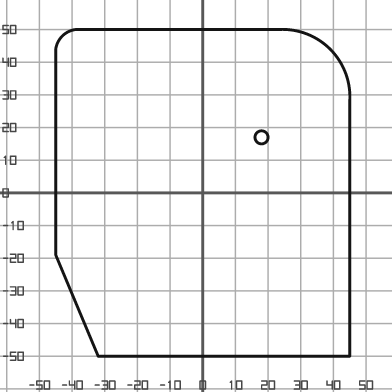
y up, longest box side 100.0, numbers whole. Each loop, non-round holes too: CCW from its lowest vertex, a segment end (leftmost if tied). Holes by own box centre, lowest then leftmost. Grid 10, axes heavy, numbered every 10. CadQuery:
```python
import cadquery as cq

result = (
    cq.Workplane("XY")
    .moveTo(-32.0, -50.0)
    .lineTo(45.0, -50.0)
    .lineTo(45.0, 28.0)
    .threePointArc((39.0, 44.0), (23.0, 50.0))
    .lineTo(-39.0, 50.0)
    .threePointArc((-43.0, 48.0), (-45.0, 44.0))
    .lineTo(-45.0, -19.0)
    .close()
    .moveTo(18.0, 17.0)
    .circle(2.0)
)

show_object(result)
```